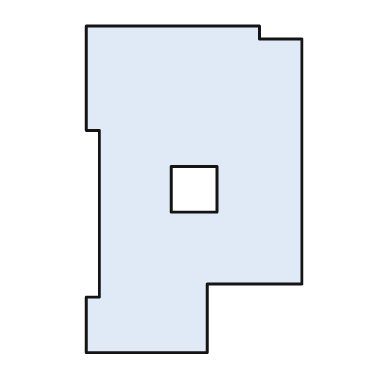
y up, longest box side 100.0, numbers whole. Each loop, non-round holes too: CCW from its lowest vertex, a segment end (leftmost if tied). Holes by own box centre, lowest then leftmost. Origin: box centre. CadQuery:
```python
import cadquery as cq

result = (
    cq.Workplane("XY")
    .moveTo(-33.0, -50.0)
    .lineTo(4.0, -50.0)
    .lineTo(4.0, -29.0)
    .lineTo(33.0, -29.0)
    .lineTo(33.0, 46.0)
    .lineTo(20.0, 46.0)
    .lineTo(20.0, 50.0)
    .lineTo(-33.0, 50.0)
    .lineTo(-33.0, 18.0)
    .lineTo(-29.0, 18.0)
    .lineTo(-29.0, -33.0)
    .lineTo(-33.0, -33.0)
    .close()
    .moveTo(-7.0, -7.0)
    .lineTo(7.0, -7.0)
    .lineTo(7.0, 7.0)
    .lineTo(-7.0, 7.0)
    .close()
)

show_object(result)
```